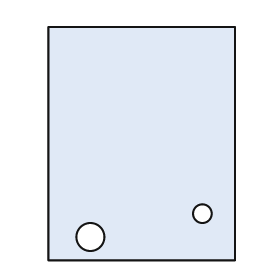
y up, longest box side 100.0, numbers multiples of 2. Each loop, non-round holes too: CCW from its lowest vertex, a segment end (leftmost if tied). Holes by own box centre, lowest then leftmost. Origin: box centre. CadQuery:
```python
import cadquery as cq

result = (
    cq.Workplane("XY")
    .moveTo(-40.0, -50.0)
    .lineTo(40.0, -50.0)
    .lineTo(40.0, 50.0)
    .lineTo(-40.0, 50.0)
    .close()
    .moveTo(-22.0, -40.0)
    .circle(6.0)
    .moveTo(26.0, -30.0)
    .circle(4.0)
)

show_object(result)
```